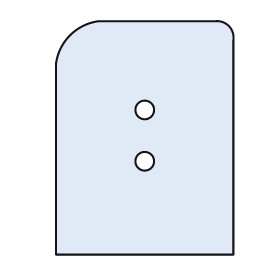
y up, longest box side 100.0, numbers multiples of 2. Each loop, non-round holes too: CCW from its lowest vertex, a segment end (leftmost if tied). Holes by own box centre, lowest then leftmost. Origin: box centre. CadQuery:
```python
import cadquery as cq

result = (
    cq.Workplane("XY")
    .moveTo(-38.0, -50.0)
    .lineTo(38.0, -50.0)
    .lineTo(38.0, 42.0)
    .threePointArc((36.0, 48.0), (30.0, 50.0))
    .lineTo(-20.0, 50.0)
    .threePointArc((-32.0, 44.0), (-38.0, 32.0))
    .close()
    .moveTo(0.0, -10.0)
    .circle(4.0)
    .moveTo(0.0, 12.0)
    .circle(4.0)
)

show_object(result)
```